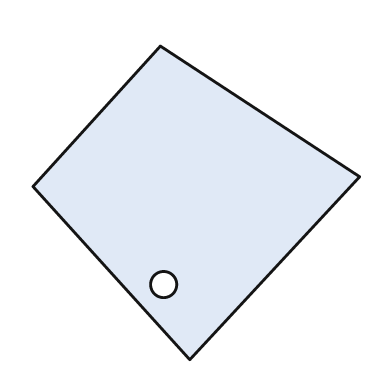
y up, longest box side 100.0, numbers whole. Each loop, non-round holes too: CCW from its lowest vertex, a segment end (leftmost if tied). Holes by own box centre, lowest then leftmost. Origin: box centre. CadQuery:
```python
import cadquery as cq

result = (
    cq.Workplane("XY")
    .moveTo(-2.0, -48.0)
    .lineTo(50.0, 8.0)
    .lineTo(-11.0, 48.0)
    .lineTo(-50.0, 5.0)
    .close()
    .moveTo(-10.0, -25.0)
    .circle(4.0)
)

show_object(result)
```